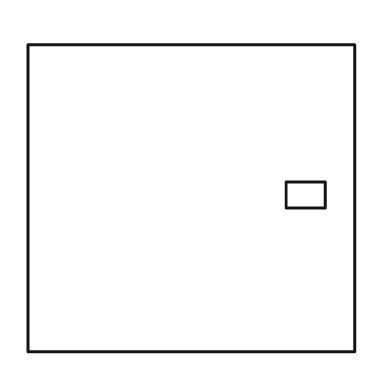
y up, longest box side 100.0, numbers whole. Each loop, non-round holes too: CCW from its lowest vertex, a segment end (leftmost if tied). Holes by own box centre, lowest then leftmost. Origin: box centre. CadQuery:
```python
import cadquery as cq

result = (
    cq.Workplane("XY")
    .moveTo(-50.0, -47.0)
    .lineTo(50.0, -47.0)
    .lineTo(50.0, 47.0)
    .lineTo(-50.0, 47.0)
    .close()
    .moveTo(29.0, -3.0)
    .lineTo(41.0, -3.0)
    .lineTo(41.0, 5.0)
    .lineTo(29.0, 5.0)
    .close()
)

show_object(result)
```